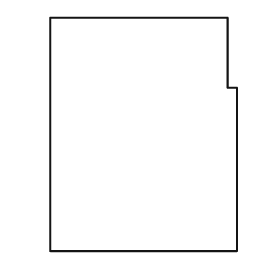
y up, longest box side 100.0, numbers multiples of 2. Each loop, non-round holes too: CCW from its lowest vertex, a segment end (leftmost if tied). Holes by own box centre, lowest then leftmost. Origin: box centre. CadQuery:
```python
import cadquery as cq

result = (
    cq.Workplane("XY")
    .moveTo(-40.0, -50.0)
    .lineTo(40.0, -50.0)
    .lineTo(40.0, 20.0)
    .lineTo(36.0, 20.0)
    .lineTo(36.0, 50.0)
    .lineTo(-40.0, 50.0)
    .close()
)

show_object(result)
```